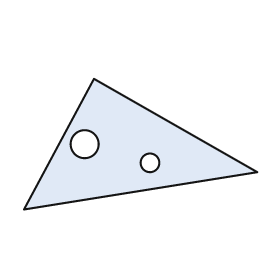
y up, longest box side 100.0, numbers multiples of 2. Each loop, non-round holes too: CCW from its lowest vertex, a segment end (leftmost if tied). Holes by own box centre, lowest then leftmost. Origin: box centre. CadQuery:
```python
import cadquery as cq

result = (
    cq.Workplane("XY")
    .moveTo(-50.0, -28.0)
    .lineTo(50.0, -12.0)
    .lineTo(-20.0, 28.0)
    .close()
    .moveTo(4.0, -8.0)
    .circle(4.0)
    .moveTo(-24.0, 0.0)
    .circle(6.0)
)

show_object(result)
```